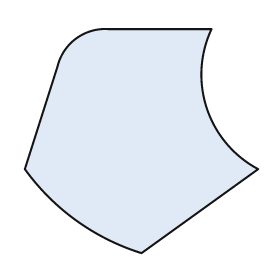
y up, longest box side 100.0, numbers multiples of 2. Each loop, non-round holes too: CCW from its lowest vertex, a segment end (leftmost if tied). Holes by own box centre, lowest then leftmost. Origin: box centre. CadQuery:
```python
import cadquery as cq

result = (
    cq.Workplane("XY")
    .moveTo(0.0, -48.0)
    .lineTo(50.0, -12.0)
    .threePointArc((28.0, 14.0), (30.0, 48.0))
    .lineTo(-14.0, 48.0)
    .threePointArc((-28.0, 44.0), (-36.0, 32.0))
    .lineTo(-50.0, -12.0)
    .threePointArc((-28.0, -34.0), (0.0, -48.0))
    .close()
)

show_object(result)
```